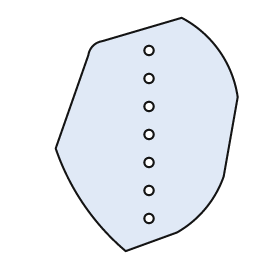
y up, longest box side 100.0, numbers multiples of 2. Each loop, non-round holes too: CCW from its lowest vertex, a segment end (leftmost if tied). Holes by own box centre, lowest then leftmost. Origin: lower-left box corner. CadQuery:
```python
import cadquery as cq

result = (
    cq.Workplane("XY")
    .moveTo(30.0, 0.0)
    .lineTo(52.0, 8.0)
    .threePointArc((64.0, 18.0), (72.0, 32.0))
    .lineTo(78.0, 66.0)
    .threePointArc((70.0, 86.0), (54.0, 100.0))
    .lineTo(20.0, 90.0)
    .threePointArc((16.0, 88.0), (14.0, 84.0))
    .lineTo(0.0, 44.0)
    .threePointArc((12.0, 20.0), (30.0, 0.0))
    .close()
    .moveTo(40.0, 14.0)
    .circle(2.0)
    .moveTo(40.0, 26.0)
    .circle(2.0)
    .moveTo(40.0, 38.0)
    .circle(2.0)
    .moveTo(40.0, 50.0)
    .circle(2.0)
    .moveTo(40.0, 62.0)
    .circle(2.0)
    .moveTo(40.0, 74.0)
    .circle(2.0)
    .moveTo(40.0, 86.0)
    .circle(2.0)
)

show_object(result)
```